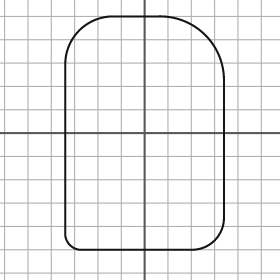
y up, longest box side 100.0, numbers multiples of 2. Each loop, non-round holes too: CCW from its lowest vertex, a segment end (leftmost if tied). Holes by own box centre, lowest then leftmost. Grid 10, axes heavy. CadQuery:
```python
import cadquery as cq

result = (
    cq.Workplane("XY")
    .moveTo(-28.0, -50.0)
    .lineTo(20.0, -50.0)
    .threePointArc((30.0, -46.0), (34.0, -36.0))
    .lineTo(34.0, 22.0)
    .threePointArc((26.0, 42.0), (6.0, 50.0))
    .lineTo(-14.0, 50.0)
    .threePointArc((-28.0, 44.0), (-34.0, 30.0))
    .lineTo(-34.0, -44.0)
    .threePointArc((-32.0, -48.0), (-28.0, -50.0))
    .close()
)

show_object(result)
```